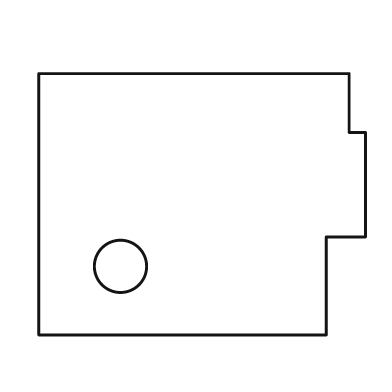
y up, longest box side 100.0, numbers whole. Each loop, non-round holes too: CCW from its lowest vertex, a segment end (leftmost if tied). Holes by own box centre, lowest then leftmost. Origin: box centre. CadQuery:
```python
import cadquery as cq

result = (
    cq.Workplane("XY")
    .moveTo(-50.0, -40.0)
    .lineTo(38.0, -40.0)
    .lineTo(38.0, -10.0)
    .lineTo(50.0, -10.0)
    .lineTo(50.0, 22.0)
    .lineTo(45.0, 22.0)
    .lineTo(45.0, 40.0)
    .lineTo(-50.0, 40.0)
    .close()
    .moveTo(-25.0, -19.0)
    .circle(8.0)
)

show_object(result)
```